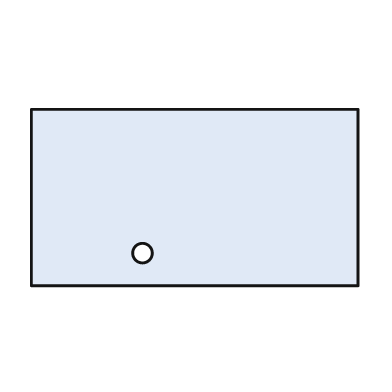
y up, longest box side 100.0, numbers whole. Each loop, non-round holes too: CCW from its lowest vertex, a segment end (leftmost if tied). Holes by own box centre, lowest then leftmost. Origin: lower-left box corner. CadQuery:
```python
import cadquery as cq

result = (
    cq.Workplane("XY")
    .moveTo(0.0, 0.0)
    .lineTo(100.0, 0.0)
    .lineTo(100.0, 54.0)
    .lineTo(0.0, 54.0)
    .close()
    .moveTo(34.0, 10.0)
    .circle(3.0)
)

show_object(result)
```